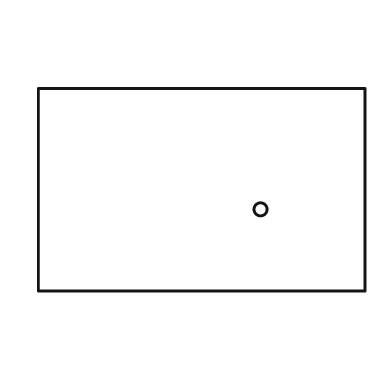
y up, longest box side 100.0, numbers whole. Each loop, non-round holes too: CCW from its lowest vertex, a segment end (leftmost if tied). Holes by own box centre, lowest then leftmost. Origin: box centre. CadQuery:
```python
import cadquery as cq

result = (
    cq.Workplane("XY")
    .moveTo(-50.0, -31.0)
    .lineTo(50.0, -31.0)
    .lineTo(50.0, 31.0)
    .lineTo(-50.0, 31.0)
    .close()
    .moveTo(18.0, -6.0)
    .circle(2.0)
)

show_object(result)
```